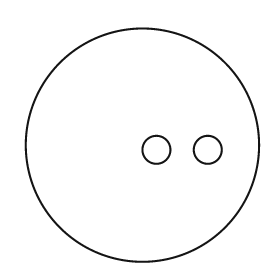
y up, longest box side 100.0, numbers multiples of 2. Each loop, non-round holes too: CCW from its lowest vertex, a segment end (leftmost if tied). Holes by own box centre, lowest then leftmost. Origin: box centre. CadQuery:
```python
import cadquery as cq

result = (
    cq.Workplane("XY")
    .moveTo(0.0, 0.0)
    .circle(50.0)
    .moveTo(6.0, -2.0)
    .circle(6.0)
    .moveTo(28.0, -2.0)
    .circle(6.0)
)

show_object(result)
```